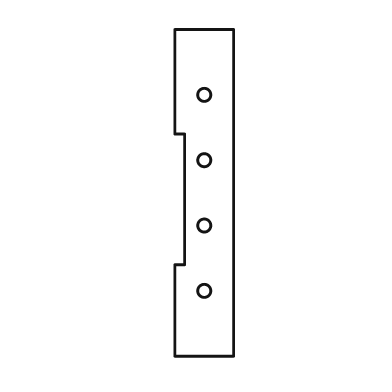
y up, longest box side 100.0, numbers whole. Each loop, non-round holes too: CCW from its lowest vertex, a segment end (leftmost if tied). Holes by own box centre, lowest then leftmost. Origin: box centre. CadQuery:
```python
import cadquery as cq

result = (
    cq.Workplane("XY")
    .moveTo(-9.0, -50.0)
    .lineTo(9.0, -50.0)
    .lineTo(9.0, 50.0)
    .lineTo(-9.0, 50.0)
    .lineTo(-9.0, 18.0)
    .lineTo(-6.0, 18.0)
    .lineTo(-6.0, -22.0)
    .lineTo(-9.0, -22.0)
    .close()
    .moveTo(0.0, -30.0)
    .circle(2.0)
    .moveTo(0.0, -10.0)
    .circle(2.0)
    .moveTo(0.0, 10.0)
    .circle(2.0)
    .moveTo(0.0, 30.0)
    .circle(2.0)
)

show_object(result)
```